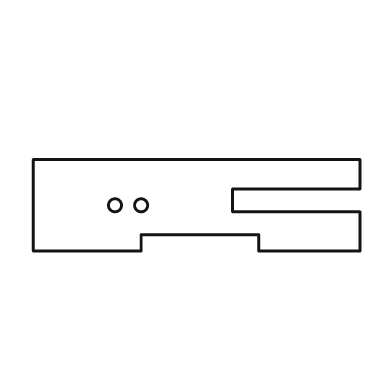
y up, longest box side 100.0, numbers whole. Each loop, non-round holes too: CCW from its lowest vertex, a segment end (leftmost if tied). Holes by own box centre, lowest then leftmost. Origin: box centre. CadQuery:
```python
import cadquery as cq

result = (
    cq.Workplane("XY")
    .moveTo(-50.0, -14.0)
    .lineTo(-17.0, -14.0)
    .lineTo(-17.0, -9.0)
    .lineTo(19.0, -9.0)
    .lineTo(19.0, -14.0)
    .lineTo(50.0, -14.0)
    .lineTo(50.0, -2.0)
    .lineTo(11.0, -2.0)
    .lineTo(11.0, 5.0)
    .lineTo(50.0, 5.0)
    .lineTo(50.0, 14.0)
    .lineTo(-50.0, 14.0)
    .close()
    .moveTo(-25.0, 0.0)
    .circle(2.0)
    .moveTo(-17.0, 0.0)
    .circle(2.0)
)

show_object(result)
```